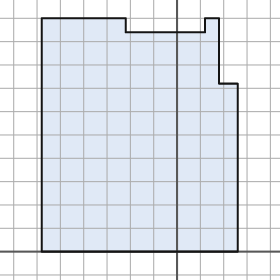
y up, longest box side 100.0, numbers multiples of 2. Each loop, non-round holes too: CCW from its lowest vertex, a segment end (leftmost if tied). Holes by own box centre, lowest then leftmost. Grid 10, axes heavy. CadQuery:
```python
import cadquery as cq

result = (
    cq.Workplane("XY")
    .moveTo(-58.0, 0.0)
    .lineTo(26.0, 0.0)
    .lineTo(26.0, 72.0)
    .lineTo(18.0, 72.0)
    .lineTo(18.0, 100.0)
    .lineTo(12.0, 100.0)
    .lineTo(12.0, 94.0)
    .lineTo(-22.0, 94.0)
    .lineTo(-22.0, 100.0)
    .lineTo(-58.0, 100.0)
    .close()
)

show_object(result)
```